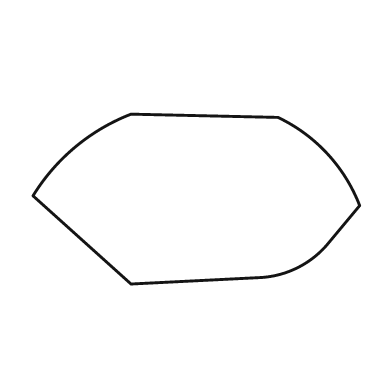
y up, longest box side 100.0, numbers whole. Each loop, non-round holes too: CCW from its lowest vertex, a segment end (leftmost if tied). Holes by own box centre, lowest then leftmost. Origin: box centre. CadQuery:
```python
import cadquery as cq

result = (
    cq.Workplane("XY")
    .moveTo(-20.0, -26.0)
    .lineTo(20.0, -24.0)
    .threePointArc((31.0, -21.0), (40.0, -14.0))
    .lineTo(50.0, -2.0)
    .threePointArc((40.0, 14.0), (25.0, 25.0))
    .lineTo(-20.0, 26.0)
    .threePointArc((-37.0, 16.0), (-50.0, 1.0))
    .close()
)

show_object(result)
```